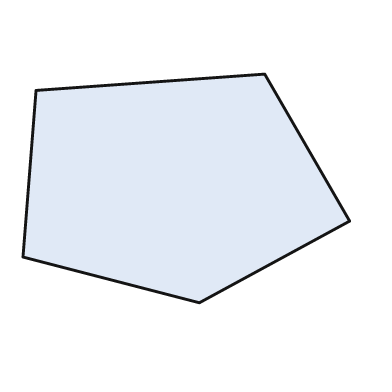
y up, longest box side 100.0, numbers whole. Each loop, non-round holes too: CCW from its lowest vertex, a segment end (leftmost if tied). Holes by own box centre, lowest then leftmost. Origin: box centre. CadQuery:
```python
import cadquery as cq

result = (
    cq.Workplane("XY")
    .moveTo(4.0, -35.0)
    .lineTo(50.0, -10.0)
    .lineTo(24.0, 35.0)
    .lineTo(-46.0, 30.0)
    .lineTo(-50.0, -21.0)
    .close()
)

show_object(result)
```